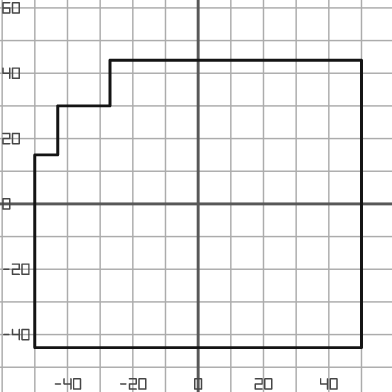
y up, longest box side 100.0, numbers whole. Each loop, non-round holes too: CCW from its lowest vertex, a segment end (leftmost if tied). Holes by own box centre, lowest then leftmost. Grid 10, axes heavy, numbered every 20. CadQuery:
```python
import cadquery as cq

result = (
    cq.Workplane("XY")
    .moveTo(-50.0, -44.0)
    .lineTo(50.0, -44.0)
    .lineTo(50.0, 44.0)
    .lineTo(-27.0, 44.0)
    .lineTo(-27.0, 30.0)
    .lineTo(-43.0, 30.0)
    .lineTo(-43.0, 15.0)
    .lineTo(-50.0, 15.0)
    .close()
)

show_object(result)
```